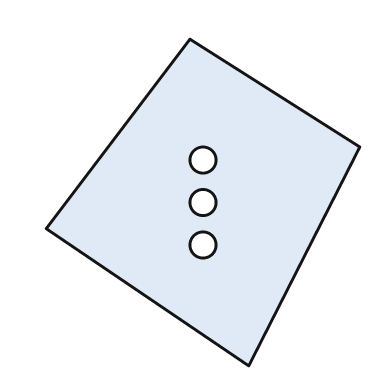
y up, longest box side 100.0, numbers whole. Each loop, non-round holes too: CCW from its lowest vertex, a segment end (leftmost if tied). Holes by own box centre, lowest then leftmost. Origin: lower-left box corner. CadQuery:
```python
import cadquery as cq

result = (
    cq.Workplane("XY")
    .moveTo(62.0, 0.0)
    .lineTo(96.0, 67.0)
    .lineTo(44.0, 100.0)
    .lineTo(0.0, 42.0)
    .close()
    .moveTo(48.0, 37.0)
    .circle(4.0)
    .moveTo(48.0, 50.0)
    .circle(4.0)
    .moveTo(48.0, 63.0)
    .circle(4.0)
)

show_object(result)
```